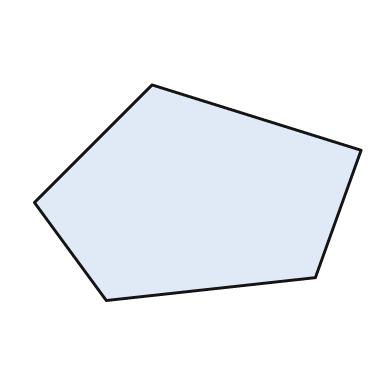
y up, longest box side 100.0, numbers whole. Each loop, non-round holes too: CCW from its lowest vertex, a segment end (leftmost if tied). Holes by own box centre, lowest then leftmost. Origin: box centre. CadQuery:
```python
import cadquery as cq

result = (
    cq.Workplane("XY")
    .moveTo(-28.0, -33.0)
    .lineTo(36.0, -26.0)
    .lineTo(50.0, 13.0)
    .lineTo(-14.0, 33.0)
    .lineTo(-50.0, -3.0)
    .close()
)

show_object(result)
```